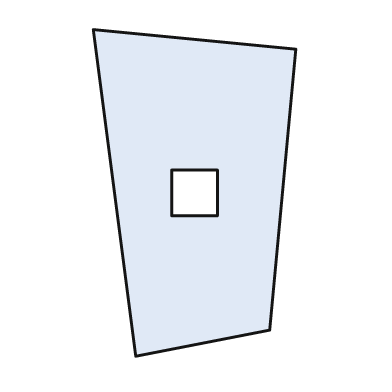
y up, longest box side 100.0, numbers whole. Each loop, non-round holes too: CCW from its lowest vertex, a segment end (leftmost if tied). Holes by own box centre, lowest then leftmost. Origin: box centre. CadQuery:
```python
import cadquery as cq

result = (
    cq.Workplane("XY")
    .moveTo(-18.0, -50.0)
    .lineTo(23.0, -42.0)
    .lineTo(31.0, 44.0)
    .lineTo(-31.0, 50.0)
    .close()
    .moveTo(-7.0, -7.0)
    .lineTo(7.0, -7.0)
    .lineTo(7.0, 7.0)
    .lineTo(-7.0, 7.0)
    .close()
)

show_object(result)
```